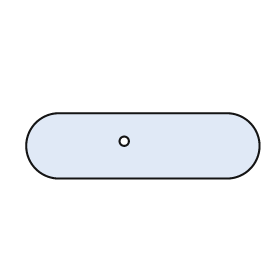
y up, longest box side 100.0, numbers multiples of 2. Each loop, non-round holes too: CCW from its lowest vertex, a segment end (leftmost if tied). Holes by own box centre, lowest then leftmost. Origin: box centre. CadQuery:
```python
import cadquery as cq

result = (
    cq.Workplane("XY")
    .moveTo(-36.0, -14.0)
    .lineTo(36.0, -14.0)
    .threePointArc((50.0, 0.0), (36.0, 14.0))
    .lineTo(-36.0, 14.0)
    .threePointArc((-50.0, 0.0), (-36.0, -14.0))
    .close()
    .moveTo(-8.0, 2.0)
    .circle(2.0)
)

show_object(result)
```